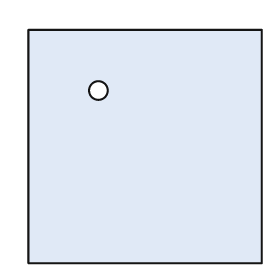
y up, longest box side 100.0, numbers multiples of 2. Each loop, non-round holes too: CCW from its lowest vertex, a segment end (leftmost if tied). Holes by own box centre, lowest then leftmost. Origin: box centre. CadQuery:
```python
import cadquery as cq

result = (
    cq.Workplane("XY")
    .moveTo(-50.0, -50.0)
    .lineTo(50.0, -50.0)
    .lineTo(50.0, 50.0)
    .lineTo(-50.0, 50.0)
    .close()
    .moveTo(-20.0, 24.0)
    .circle(4.0)
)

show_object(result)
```